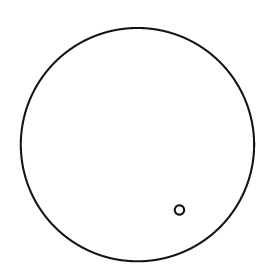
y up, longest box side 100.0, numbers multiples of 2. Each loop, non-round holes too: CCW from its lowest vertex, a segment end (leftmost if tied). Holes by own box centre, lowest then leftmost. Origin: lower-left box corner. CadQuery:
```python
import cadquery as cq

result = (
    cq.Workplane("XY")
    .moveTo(50.0, 50.0)
    .circle(50.0)
    .moveTo(68.0, 22.0)
    .circle(2.0)
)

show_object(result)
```